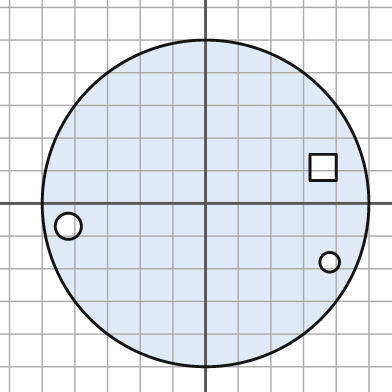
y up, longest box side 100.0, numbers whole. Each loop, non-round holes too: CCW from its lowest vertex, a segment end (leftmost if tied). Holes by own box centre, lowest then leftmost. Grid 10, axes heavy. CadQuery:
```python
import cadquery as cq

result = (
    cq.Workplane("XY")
    .moveTo(0.0, 0.0)
    .circle(50.0)
    .moveTo(38.0, -18.0)
    .circle(3.0)
    .moveTo(-42.0, -7.0)
    .circle(4.0)
    .moveTo(32.0, 7.0)
    .lineTo(40.0, 7.0)
    .lineTo(40.0, 15.0)
    .lineTo(32.0, 15.0)
    .close()
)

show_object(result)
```